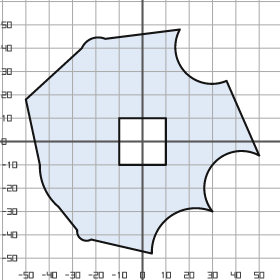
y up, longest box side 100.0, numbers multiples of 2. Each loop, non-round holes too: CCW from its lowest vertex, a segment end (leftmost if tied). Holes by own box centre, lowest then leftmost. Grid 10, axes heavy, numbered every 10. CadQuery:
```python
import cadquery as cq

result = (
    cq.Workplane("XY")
    .moveTo(4.0, -48.0)
    .threePointArc((12.0, -32.0), (30.0, -30.0))
    .threePointArc((30.0, -10.0), (50.0, -6.0))
    .lineTo(36.0, 26.0)
    .threePointArc((18.0, 30.0), (16.0, 48.0))
    .lineTo(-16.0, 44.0)
    .threePointArc((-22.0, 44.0), (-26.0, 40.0))
    .lineTo(-50.0, 18.0)
    .lineTo(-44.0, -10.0)
    .threePointArc((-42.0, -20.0), (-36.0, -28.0))
    .lineTo(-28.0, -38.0)
    .threePointArc((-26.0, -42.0), (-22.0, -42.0))
    .close()
    .moveTo(-10.0, -10.0)
    .lineTo(10.0, -10.0)
    .lineTo(10.0, 10.0)
    .lineTo(-10.0, 10.0)
    .close()
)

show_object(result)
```